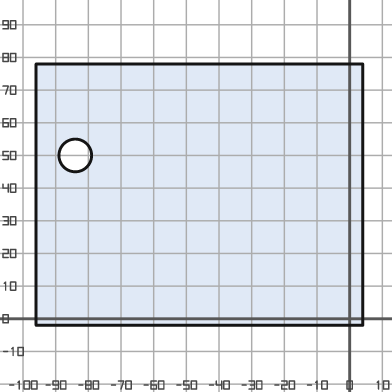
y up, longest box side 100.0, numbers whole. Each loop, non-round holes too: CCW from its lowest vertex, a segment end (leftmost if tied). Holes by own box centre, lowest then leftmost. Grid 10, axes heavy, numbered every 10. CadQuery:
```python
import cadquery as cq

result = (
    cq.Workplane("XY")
    .moveTo(-96.0, -2.0)
    .lineTo(4.0, -2.0)
    .lineTo(4.0, 78.0)
    .lineTo(-96.0, 78.0)
    .close()
    .moveTo(-84.0, 50.0)
    .circle(5.0)
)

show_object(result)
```